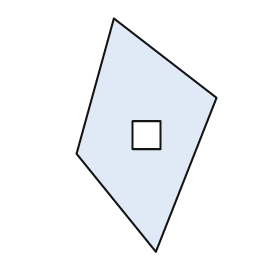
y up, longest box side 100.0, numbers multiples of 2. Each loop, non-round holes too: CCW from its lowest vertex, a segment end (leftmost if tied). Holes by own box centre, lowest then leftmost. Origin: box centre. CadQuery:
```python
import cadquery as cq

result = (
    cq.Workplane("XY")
    .moveTo(4.0, -50.0)
    .lineTo(30.0, 16.0)
    .lineTo(-14.0, 50.0)
    .lineTo(-30.0, -8.0)
    .close()
    .moveTo(-6.0, -6.0)
    .lineTo(6.0, -6.0)
    .lineTo(6.0, 6.0)
    .lineTo(-6.0, 6.0)
    .close()
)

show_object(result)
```